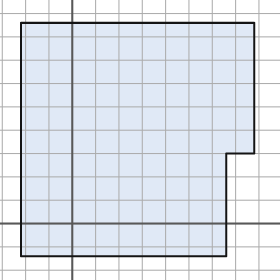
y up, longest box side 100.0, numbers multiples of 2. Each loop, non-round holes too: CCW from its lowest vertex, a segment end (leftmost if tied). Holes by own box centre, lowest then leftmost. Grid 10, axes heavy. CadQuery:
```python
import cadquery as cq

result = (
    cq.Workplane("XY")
    .moveTo(-22.0, -14.0)
    .lineTo(66.0, -14.0)
    .lineTo(66.0, 30.0)
    .lineTo(78.0, 30.0)
    .lineTo(78.0, 86.0)
    .lineTo(-22.0, 86.0)
    .close()
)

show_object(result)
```